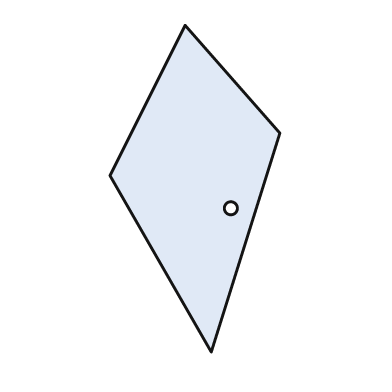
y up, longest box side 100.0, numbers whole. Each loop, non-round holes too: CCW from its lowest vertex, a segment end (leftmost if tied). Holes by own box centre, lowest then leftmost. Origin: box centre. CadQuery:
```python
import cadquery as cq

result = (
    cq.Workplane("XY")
    .moveTo(5.0, -50.0)
    .lineTo(26.0, 17.0)
    .lineTo(-3.0, 50.0)
    .lineTo(-26.0, 4.0)
    .close()
    .moveTo(11.0, -6.0)
    .circle(2.0)
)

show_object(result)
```